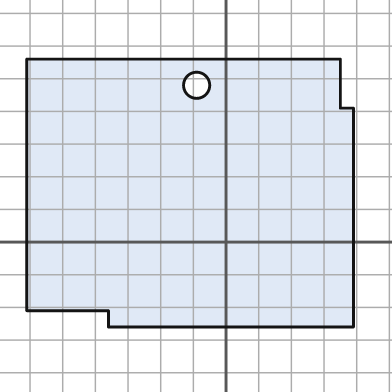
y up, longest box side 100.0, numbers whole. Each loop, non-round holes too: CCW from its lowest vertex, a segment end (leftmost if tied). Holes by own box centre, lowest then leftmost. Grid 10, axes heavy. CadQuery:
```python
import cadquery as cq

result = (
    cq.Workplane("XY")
    .moveTo(-36.0, -26.0)
    .lineTo(39.0, -26.0)
    .lineTo(39.0, 41.0)
    .lineTo(35.0, 41.0)
    .lineTo(35.0, 56.0)
    .lineTo(-61.0, 56.0)
    .lineTo(-61.0, -21.0)
    .lineTo(-36.0, -21.0)
    .close()
    .moveTo(-9.0, 48.0)
    .circle(4.0)
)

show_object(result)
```